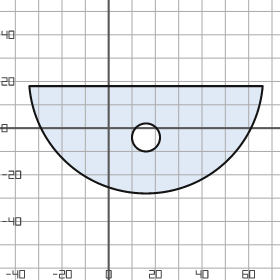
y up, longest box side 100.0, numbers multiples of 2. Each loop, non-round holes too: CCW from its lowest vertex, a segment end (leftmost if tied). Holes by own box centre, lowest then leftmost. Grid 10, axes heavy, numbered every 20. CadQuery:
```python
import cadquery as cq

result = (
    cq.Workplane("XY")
    .moveTo(-34.0, 18.0)
    .threePointArc((16.0, -28.0), (66.0, 18.0))
    .close()
    .moveTo(16.0, -4.0)
    .circle(6.0)
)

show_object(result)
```